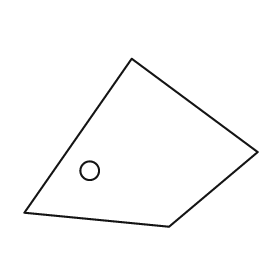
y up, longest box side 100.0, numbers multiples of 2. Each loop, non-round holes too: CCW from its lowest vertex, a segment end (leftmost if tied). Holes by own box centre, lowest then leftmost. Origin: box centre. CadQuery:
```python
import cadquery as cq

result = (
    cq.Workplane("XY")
    .moveTo(12.0, -36.0)
    .lineTo(50.0, -4.0)
    .lineTo(-4.0, 36.0)
    .lineTo(-50.0, -30.0)
    .close()
    .moveTo(-22.0, -12.0)
    .circle(4.0)
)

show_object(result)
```